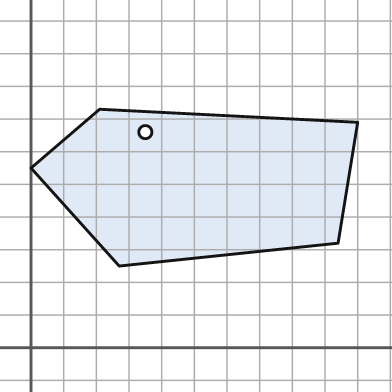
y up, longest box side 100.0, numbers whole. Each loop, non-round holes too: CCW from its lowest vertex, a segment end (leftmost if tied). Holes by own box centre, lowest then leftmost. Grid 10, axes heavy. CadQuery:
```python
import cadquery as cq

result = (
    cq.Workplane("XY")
    .moveTo(27.0, 25.0)
    .lineTo(94.0, 32.0)
    .lineTo(100.0, 69.0)
    .lineTo(21.0, 73.0)
    .lineTo(0.0, 55.0)
    .close()
    .moveTo(35.0, 66.0)
    .circle(2.0)
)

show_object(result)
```